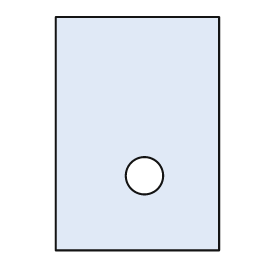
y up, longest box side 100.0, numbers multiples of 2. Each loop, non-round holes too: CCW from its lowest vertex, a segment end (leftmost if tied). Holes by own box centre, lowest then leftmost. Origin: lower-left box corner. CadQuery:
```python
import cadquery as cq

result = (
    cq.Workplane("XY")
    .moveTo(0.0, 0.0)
    .lineTo(70.0, 0.0)
    .lineTo(70.0, 100.0)
    .lineTo(0.0, 100.0)
    .close()
    .moveTo(38.0, 32.0)
    .circle(8.0)
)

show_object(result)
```